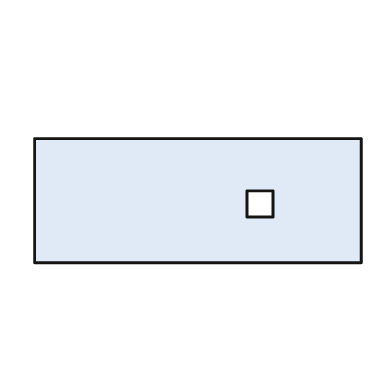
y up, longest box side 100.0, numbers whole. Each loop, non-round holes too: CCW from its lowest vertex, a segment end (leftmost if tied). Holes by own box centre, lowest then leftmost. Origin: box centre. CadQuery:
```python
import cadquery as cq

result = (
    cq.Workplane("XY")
    .moveTo(-50.0, -19.0)
    .lineTo(50.0, -19.0)
    .lineTo(50.0, 19.0)
    .lineTo(-50.0, 19.0)
    .close()
    .moveTo(15.0, -5.0)
    .lineTo(23.0, -5.0)
    .lineTo(23.0, 3.0)
    .lineTo(15.0, 3.0)
    .close()
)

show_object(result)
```